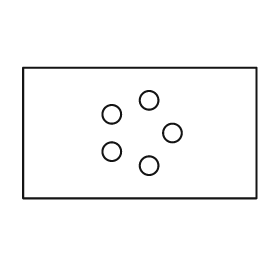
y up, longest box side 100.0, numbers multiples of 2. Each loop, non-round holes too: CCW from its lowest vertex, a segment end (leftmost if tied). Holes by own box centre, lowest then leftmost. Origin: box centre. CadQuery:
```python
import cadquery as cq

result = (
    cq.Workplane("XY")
    .moveTo(-50.0, -28.0)
    .lineTo(50.0, -28.0)
    .lineTo(50.0, 28.0)
    .lineTo(-50.0, 28.0)
    .close()
    .moveTo(4.0, -14.0)
    .circle(4.0)
    .moveTo(-12.0, -8.0)
    .circle(4.0)
    .moveTo(14.0, 0.0)
    .circle(4.0)
    .moveTo(-12.0, 8.0)
    .circle(4.0)
    .moveTo(4.0, 14.0)
    .circle(4.0)
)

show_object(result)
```